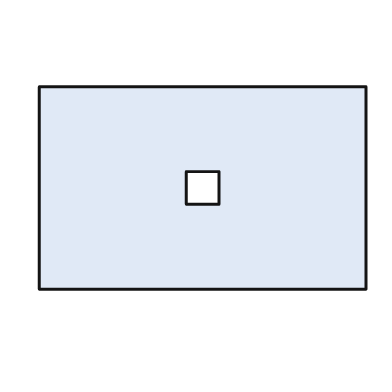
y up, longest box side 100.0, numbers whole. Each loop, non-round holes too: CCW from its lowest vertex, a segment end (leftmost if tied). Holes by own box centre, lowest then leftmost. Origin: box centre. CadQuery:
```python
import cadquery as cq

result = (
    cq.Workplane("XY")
    .moveTo(-50.0, -31.0)
    .lineTo(50.0, -31.0)
    .lineTo(50.0, 31.0)
    .lineTo(-50.0, 31.0)
    .close()
    .moveTo(-5.0, -5.0)
    .lineTo(5.0, -5.0)
    .lineTo(5.0, 5.0)
    .lineTo(-5.0, 5.0)
    .close()
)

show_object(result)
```